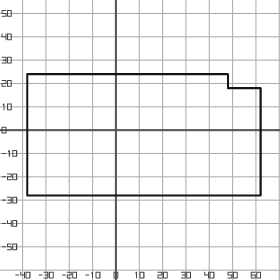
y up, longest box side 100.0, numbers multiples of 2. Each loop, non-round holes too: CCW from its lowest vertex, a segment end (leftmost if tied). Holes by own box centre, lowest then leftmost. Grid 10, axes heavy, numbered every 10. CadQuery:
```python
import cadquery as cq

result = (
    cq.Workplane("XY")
    .moveTo(-38.0, -28.0)
    .lineTo(62.0, -28.0)
    .lineTo(62.0, 18.0)
    .lineTo(48.0, 18.0)
    .lineTo(48.0, 24.0)
    .lineTo(-38.0, 24.0)
    .close()
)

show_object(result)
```